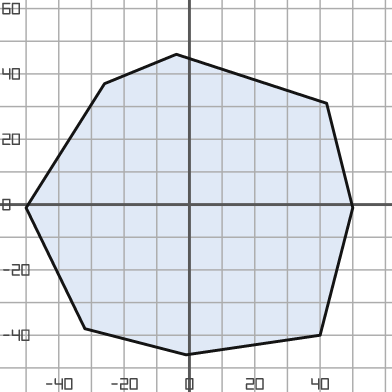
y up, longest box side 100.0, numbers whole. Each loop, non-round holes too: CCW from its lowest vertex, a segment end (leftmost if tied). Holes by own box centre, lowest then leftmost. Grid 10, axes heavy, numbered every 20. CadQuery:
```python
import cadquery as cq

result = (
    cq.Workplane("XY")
    .moveTo(-1.0, -46.0)
    .lineTo(40.0, -40.0)
    .lineTo(50.0, -1.0)
    .lineTo(42.0, 31.0)
    .lineTo(-4.0, 46.0)
    .lineTo(-26.0, 37.0)
    .lineTo(-50.0, -1.0)
    .lineTo(-32.0, -38.0)
    .close()
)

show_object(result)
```